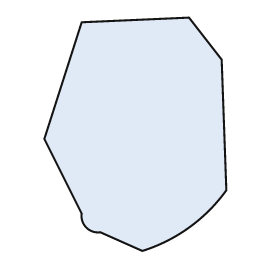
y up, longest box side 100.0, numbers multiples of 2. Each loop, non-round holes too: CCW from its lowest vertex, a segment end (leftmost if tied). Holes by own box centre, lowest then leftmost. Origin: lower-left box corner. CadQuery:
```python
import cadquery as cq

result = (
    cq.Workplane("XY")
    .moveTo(42.0, 0.0)
    .threePointArc((62.0, 10.0), (78.0, 26.0))
    .lineTo(76.0, 82.0)
    .lineTo(62.0, 100.0)
    .lineTo(16.0, 98.0)
    .lineTo(0.0, 48.0)
    .lineTo(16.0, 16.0)
    .threePointArc((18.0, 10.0), (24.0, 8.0))
    .close()
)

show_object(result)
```